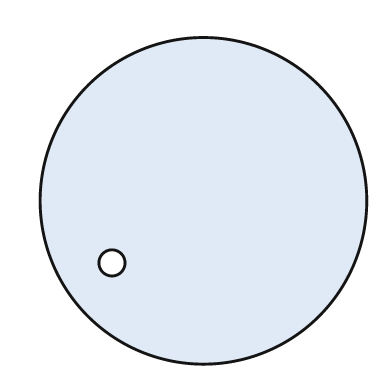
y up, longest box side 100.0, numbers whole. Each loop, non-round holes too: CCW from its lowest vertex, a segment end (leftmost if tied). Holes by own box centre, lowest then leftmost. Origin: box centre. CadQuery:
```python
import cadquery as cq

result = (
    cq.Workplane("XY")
    .moveTo(0.0, 0.0)
    .circle(50.0)
    .moveTo(-28.0, -19.0)
    .circle(4.0)
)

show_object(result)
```